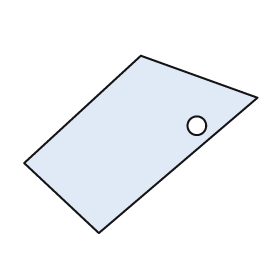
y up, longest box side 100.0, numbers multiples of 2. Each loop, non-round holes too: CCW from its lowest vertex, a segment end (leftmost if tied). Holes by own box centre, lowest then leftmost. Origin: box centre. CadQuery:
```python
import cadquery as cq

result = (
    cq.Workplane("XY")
    .moveTo(-18.0, -38.0)
    .lineTo(50.0, 20.0)
    .lineTo(0.0, 38.0)
    .lineTo(-50.0, -8.0)
    .close()
    .moveTo(24.0, 8.0)
    .circle(4.0)
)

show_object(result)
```